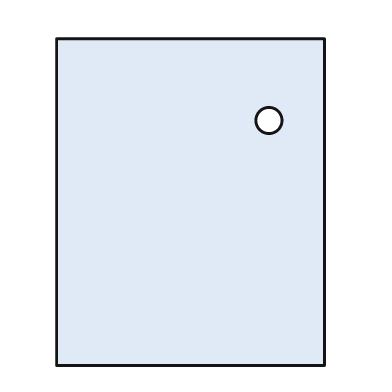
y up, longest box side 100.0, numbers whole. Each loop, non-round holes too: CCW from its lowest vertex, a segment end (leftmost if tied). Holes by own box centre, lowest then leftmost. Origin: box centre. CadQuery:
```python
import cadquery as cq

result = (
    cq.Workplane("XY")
    .moveTo(-41.0, -50.0)
    .lineTo(41.0, -50.0)
    .lineTo(41.0, 50.0)
    .lineTo(-41.0, 50.0)
    .close()
    .moveTo(24.0, 25.0)
    .circle(4.0)
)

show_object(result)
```